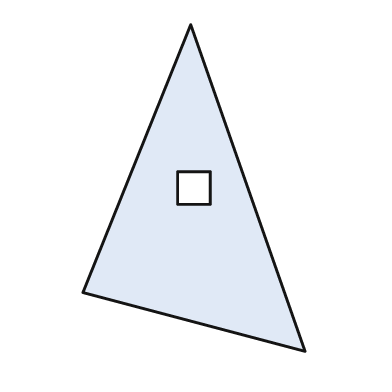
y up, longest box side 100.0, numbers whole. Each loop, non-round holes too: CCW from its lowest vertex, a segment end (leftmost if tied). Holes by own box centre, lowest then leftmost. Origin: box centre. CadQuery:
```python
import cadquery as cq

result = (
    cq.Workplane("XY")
    .moveTo(34.0, -50.0)
    .lineTo(-1.0, 50.0)
    .lineTo(-34.0, -32.0)
    .close()
    .moveTo(-5.0, -5.0)
    .lineTo(5.0, -5.0)
    .lineTo(5.0, 5.0)
    .lineTo(-5.0, 5.0)
    .close()
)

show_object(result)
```